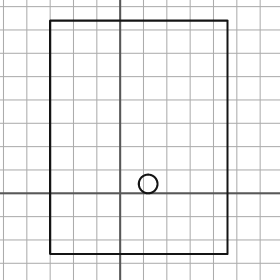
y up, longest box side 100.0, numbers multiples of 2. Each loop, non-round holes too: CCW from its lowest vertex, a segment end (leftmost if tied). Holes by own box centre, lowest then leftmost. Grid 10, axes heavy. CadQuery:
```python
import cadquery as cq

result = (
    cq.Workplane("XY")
    .moveTo(-30.0, -26.0)
    .lineTo(46.0, -26.0)
    .lineTo(46.0, 74.0)
    .lineTo(-30.0, 74.0)
    .close()
    .moveTo(12.0, 4.0)
    .circle(4.0)
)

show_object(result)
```